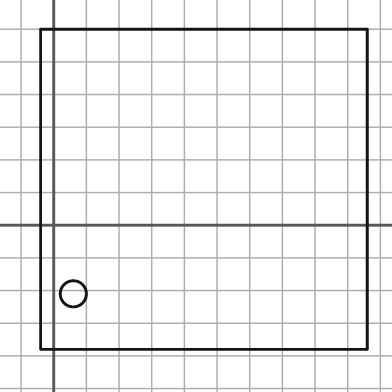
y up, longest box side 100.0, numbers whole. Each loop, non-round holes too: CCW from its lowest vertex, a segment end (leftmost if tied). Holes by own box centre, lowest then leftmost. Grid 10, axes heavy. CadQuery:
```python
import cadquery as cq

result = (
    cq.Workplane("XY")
    .moveTo(-4.0, -38.0)
    .lineTo(96.0, -38.0)
    .lineTo(96.0, 60.0)
    .lineTo(-4.0, 60.0)
    .close()
    .moveTo(6.0, -21.0)
    .circle(4.0)
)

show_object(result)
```